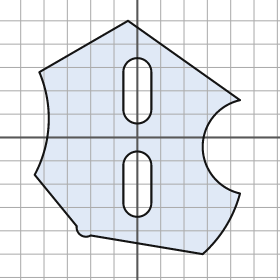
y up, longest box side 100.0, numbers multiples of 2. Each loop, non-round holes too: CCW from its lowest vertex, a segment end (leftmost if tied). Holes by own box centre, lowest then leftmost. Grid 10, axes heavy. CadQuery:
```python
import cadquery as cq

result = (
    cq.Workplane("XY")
    .moveTo(28.0, -50.0)
    .threePointArc((38.0, -38.0), (44.0, -24.0))
    .threePointArc((28.0, -4.0), (44.0, 16.0))
    .lineTo(-4.0, 50.0)
    .lineTo(-42.0, 28.0)
    .threePointArc((-38.0, 6.0), (-44.0, -16.0))
    .lineTo(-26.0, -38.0)
    .threePointArc((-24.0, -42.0), (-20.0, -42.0))
    .close()
    .moveTo(-6.0, -28.0)
    .threePointArc((0.0, -34.0), (6.0, -28.0))
    .lineTo(6.0, -12.0)
    .threePointArc((0.0, -6.0), (-6.0, -12.0))
    .close()
    .moveTo(-6.0, 12.0)
    .threePointArc((0.0, 6.0), (6.0, 12.0))
    .lineTo(6.0, 28.0)
    .threePointArc((0.0, 34.0), (-6.0, 28.0))
    .close()
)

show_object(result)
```